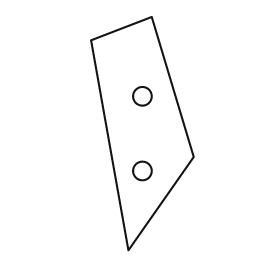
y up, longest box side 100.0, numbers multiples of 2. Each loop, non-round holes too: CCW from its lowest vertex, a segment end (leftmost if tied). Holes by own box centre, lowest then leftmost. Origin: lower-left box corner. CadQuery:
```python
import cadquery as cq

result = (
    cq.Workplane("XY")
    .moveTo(16.0, 0.0)
    .lineTo(44.0, 40.0)
    .lineTo(26.0, 100.0)
    .lineTo(0.0, 90.0)
    .close()
    .moveTo(22.0, 34.0)
    .circle(4.0)
    .moveTo(22.0, 66.0)
    .circle(4.0)
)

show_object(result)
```